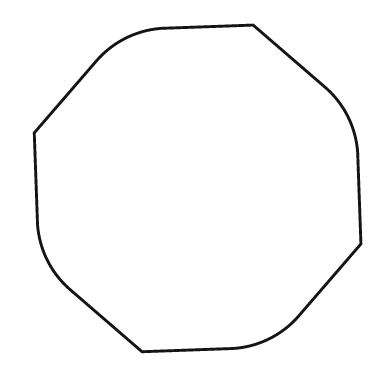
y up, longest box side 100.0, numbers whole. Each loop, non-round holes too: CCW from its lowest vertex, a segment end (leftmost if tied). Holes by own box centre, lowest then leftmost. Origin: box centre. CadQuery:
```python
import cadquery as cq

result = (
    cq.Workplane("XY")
    .moveTo(-17.0, -50.0)
    .lineTo(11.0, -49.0)
    .threePointArc((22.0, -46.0), (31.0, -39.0))
    .lineTo(50.0, -17.0)
    .lineTo(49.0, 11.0)
    .threePointArc((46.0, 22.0), (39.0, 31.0))
    .lineTo(17.0, 50.0)
    .lineTo(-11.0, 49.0)
    .threePointArc((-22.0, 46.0), (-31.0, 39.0))
    .lineTo(-50.0, 17.0)
    .lineTo(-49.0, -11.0)
    .threePointArc((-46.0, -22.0), (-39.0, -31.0))
    .close()
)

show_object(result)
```